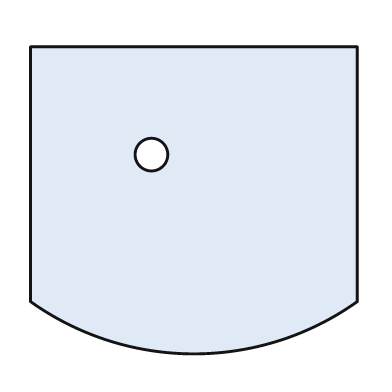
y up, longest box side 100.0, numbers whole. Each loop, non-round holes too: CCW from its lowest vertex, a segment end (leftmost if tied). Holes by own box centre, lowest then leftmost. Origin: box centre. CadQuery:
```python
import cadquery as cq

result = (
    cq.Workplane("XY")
    .moveTo(-50.0, -31.0)
    .threePointArc((0.0, -47.0), (50.0, -31.0))
    .lineTo(50.0, 47.0)
    .lineTo(-50.0, 47.0)
    .close()
    .moveTo(-13.0, 14.0)
    .circle(5.0)
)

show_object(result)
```